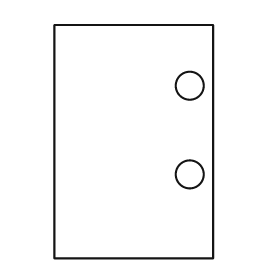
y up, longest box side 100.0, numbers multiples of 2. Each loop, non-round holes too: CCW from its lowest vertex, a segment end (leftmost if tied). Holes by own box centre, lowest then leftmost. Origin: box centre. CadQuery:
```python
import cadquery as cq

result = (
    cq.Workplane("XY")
    .moveTo(-34.0, -50.0)
    .lineTo(34.0, -50.0)
    .lineTo(34.0, 50.0)
    .lineTo(-34.0, 50.0)
    .close()
    .moveTo(24.0, -14.0)
    .circle(6.0)
    .moveTo(24.0, 24.0)
    .circle(6.0)
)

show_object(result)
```